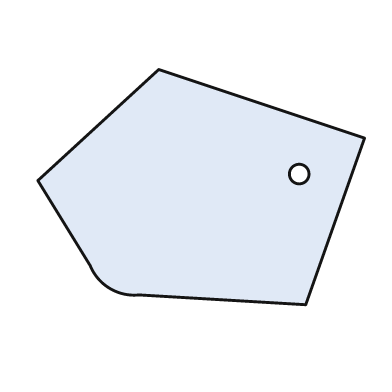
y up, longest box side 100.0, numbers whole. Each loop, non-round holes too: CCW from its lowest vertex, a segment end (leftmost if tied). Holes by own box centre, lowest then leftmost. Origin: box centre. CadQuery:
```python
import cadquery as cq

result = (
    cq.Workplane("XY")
    .moveTo(32.0, -36.0)
    .lineTo(50.0, 15.0)
    .lineTo(-13.0, 36.0)
    .lineTo(-50.0, 2.0)
    .lineTo(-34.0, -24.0)
    .threePointArc((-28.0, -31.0), (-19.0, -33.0))
    .close()
    .moveTo(30.0, 4.0)
    .circle(3.0)
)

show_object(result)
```